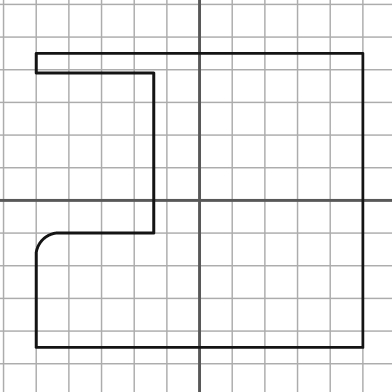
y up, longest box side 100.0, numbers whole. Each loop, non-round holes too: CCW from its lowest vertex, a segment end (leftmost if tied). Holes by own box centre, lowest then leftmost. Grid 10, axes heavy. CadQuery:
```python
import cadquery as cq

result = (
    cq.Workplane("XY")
    .moveTo(-50.0, -45.0)
    .lineTo(50.0, -45.0)
    .lineTo(50.0, 45.0)
    .lineTo(-50.0, 45.0)
    .lineTo(-50.0, 39.0)
    .lineTo(-14.0, 39.0)
    .lineTo(-14.0, -10.0)
    .lineTo(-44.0, -10.0)
    .threePointArc((-48.0, -12.0), (-50.0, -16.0))
    .close()
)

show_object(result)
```